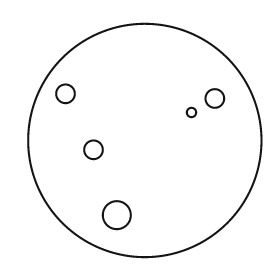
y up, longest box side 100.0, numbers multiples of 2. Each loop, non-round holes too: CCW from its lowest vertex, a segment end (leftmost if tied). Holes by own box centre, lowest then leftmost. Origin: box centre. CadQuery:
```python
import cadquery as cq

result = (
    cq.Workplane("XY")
    .moveTo(0.0, 0.0)
    .circle(50.0)
    .moveTo(-12.0, -32.0)
    .circle(6.0)
    .moveTo(-22.0, -4.0)
    .circle(4.0)
    .moveTo(20.0, 12.0)
    .circle(2.0)
    .moveTo(30.0, 18.0)
    .circle(4.0)
    .moveTo(-34.0, 20.0)
    .circle(4.0)
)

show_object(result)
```